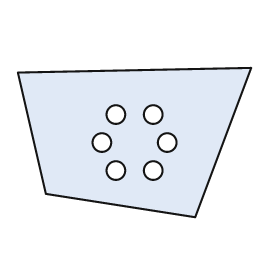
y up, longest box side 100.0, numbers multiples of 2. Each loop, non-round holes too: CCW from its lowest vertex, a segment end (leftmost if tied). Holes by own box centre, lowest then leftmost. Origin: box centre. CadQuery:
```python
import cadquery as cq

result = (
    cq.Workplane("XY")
    .moveTo(26.0, -32.0)
    .lineTo(50.0, 32.0)
    .lineTo(-50.0, 30.0)
    .lineTo(-38.0, -22.0)
    .close()
    .moveTo(-8.0, -12.0)
    .circle(4.0)
    .moveTo(8.0, -12.0)
    .circle(4.0)
    .moveTo(-14.0, 0.0)
    .circle(4.0)
    .moveTo(14.0, 0.0)
    .circle(4.0)
    .moveTo(-8.0, 12.0)
    .circle(4.0)
    .moveTo(8.0, 12.0)
    .circle(4.0)
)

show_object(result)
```